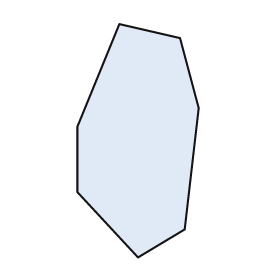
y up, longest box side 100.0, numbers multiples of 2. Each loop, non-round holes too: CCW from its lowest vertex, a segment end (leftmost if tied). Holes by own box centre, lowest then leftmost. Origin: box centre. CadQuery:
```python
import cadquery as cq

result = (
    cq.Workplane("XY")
    .moveTo(0.0, -50.0)
    .lineTo(20.0, -38.0)
    .lineTo(26.0, 14.0)
    .lineTo(18.0, 44.0)
    .lineTo(-8.0, 50.0)
    .lineTo(-26.0, 6.0)
    .lineTo(-26.0, -22.0)
    .close()
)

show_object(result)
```